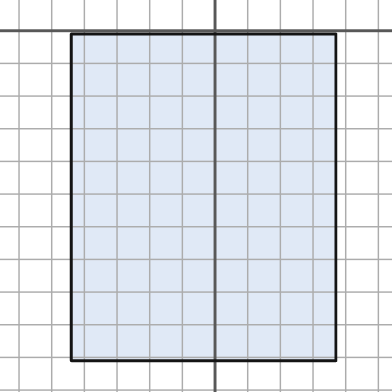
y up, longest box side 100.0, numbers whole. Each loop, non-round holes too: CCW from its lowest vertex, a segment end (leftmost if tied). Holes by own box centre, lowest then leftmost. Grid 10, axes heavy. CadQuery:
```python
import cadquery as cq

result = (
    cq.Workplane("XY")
    .moveTo(-44.0, -101.0)
    .lineTo(37.0, -101.0)
    .lineTo(37.0, -1.0)
    .lineTo(-44.0, -1.0)
    .close()
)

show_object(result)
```